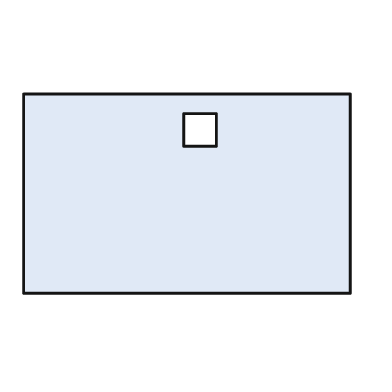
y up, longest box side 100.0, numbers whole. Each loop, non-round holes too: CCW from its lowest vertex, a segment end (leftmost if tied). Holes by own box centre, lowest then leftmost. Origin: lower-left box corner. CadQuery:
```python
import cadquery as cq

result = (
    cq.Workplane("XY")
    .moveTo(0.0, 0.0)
    .lineTo(100.0, 0.0)
    .lineTo(100.0, 61.0)
    .lineTo(0.0, 61.0)
    .close()
    .moveTo(49.0, 45.0)
    .lineTo(59.0, 45.0)
    .lineTo(59.0, 55.0)
    .lineTo(49.0, 55.0)
    .close()
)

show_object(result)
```